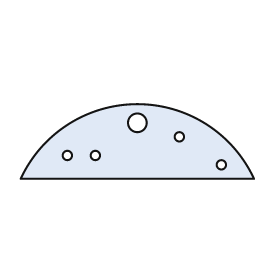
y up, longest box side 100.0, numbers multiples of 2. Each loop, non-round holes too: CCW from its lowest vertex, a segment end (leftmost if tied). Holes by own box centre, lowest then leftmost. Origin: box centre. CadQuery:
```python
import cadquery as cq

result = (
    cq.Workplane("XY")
    .moveTo(-50.0, -16.0)
    .lineTo(50.0, -16.0)
    .threePointArc((0.0, 16.0), (-50.0, -16.0))
    .close()
    .moveTo(36.0, -10.0)
    .circle(2.0)
    .moveTo(-30.0, -6.0)
    .circle(2.0)
    .moveTo(-18.0, -6.0)
    .circle(2.0)
    .moveTo(18.0, 2.0)
    .circle(2.0)
    .moveTo(0.0, 8.0)
    .circle(4.0)
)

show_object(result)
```